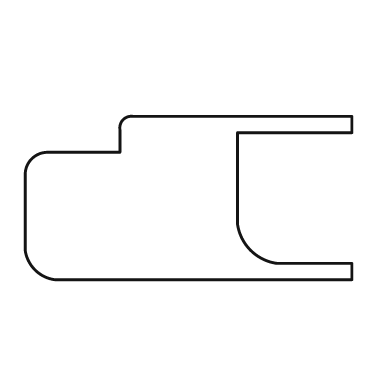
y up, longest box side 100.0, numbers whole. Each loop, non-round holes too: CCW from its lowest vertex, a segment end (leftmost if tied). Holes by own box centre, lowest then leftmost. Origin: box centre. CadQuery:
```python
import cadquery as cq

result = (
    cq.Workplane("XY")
    .moveTo(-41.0, -25.0)
    .lineTo(50.0, -25.0)
    .lineTo(50.0, -20.0)
    .lineTo(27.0, -20.0)
    .threePointArc((19.0, -16.0), (15.0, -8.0))
    .lineTo(15.0, 20.0)
    .lineTo(50.0, 20.0)
    .lineTo(50.0, 25.0)
    .lineTo(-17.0, 25.0)
    .threePointArc((-20.0, 24.0), (-21.0, 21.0))
    .lineTo(-21.0, 14.0)
    .lineTo(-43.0, 14.0)
    .threePointArc((-48.0, 12.0), (-50.0, 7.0))
    .lineTo(-50.0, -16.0)
    .threePointArc((-47.0, -22.0), (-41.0, -25.0))
    .close()
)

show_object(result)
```